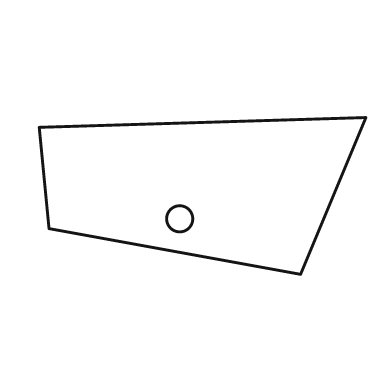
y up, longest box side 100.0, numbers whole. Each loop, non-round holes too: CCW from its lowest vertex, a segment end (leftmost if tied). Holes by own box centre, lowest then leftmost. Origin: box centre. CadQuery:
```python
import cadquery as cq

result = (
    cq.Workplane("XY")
    .moveTo(30.0, -24.0)
    .lineTo(50.0, 24.0)
    .lineTo(-50.0, 21.0)
    .lineTo(-47.0, -10.0)
    .close()
    .moveTo(-7.0, -7.0)
    .circle(4.0)
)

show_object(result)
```